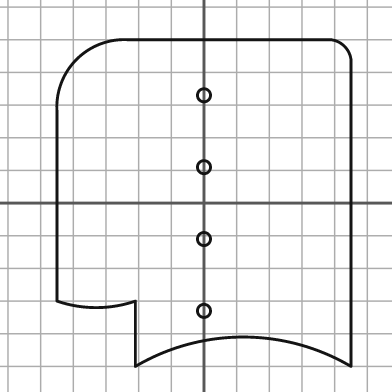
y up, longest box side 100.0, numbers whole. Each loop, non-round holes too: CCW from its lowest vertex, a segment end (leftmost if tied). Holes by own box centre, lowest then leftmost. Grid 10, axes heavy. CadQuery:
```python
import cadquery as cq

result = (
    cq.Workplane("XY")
    .moveTo(-21.0, -50.0)
    .threePointArc((12.0, -41.0), (45.0, -50.0))
    .lineTo(45.0, 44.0)
    .threePointArc((43.0, 48.0), (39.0, 50.0))
    .lineTo(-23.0, 50.0)
    .threePointArc((-39.0, 44.0), (-45.0, 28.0))
    .lineTo(-45.0, -30.0)
    .threePointArc((-33.0, -32.0), (-21.0, -30.0))
    .close()
    .moveTo(0.0, -33.0)
    .circle(2.0)
    .moveTo(0.0, -11.0)
    .circle(2.0)
    .moveTo(0.0, 11.0)
    .circle(2.0)
    .moveTo(0.0, 33.0)
    .circle(2.0)
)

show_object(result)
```